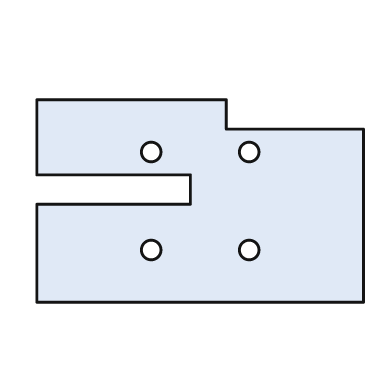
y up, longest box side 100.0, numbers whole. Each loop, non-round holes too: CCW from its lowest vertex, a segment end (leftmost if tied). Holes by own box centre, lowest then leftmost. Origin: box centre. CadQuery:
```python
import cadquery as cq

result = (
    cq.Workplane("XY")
    .moveTo(-50.0, -31.0)
    .lineTo(50.0, -31.0)
    .lineTo(50.0, 22.0)
    .lineTo(8.0, 22.0)
    .lineTo(8.0, 31.0)
    .lineTo(-50.0, 31.0)
    .lineTo(-50.0, 8.0)
    .lineTo(-3.0, 8.0)
    .lineTo(-3.0, -1.0)
    .lineTo(-50.0, -1.0)
    .close()
    .moveTo(-15.0, -15.0)
    .circle(3.0)
    .moveTo(15.0, -15.0)
    .circle(3.0)
    .moveTo(-15.0, 15.0)
    .circle(3.0)
    .moveTo(15.0, 15.0)
    .circle(3.0)
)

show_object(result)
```